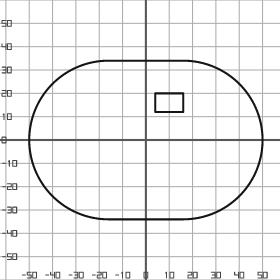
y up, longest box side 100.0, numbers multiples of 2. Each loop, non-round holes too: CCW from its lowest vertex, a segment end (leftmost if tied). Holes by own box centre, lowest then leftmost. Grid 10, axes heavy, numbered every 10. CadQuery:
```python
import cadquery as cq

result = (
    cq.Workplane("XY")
    .moveTo(-16.0, -34.0)
    .lineTo(16.0, -34.0)
    .threePointArc((50.0, 0.0), (16.0, 34.0))
    .lineTo(-16.0, 34.0)
    .threePointArc((-50.0, 0.0), (-16.0, -34.0))
    .close()
    .moveTo(4.0, 12.0)
    .lineTo(16.0, 12.0)
    .lineTo(16.0, 20.0)
    .lineTo(4.0, 20.0)
    .close()
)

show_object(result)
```